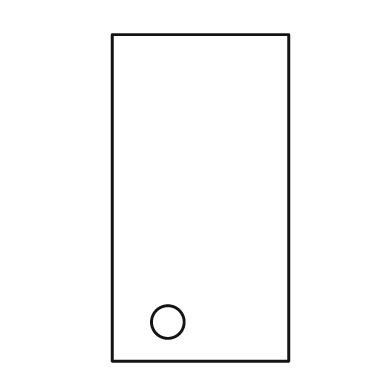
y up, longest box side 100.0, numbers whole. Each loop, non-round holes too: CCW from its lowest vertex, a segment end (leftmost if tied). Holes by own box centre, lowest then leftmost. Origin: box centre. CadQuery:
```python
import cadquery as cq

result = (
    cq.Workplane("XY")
    .moveTo(-27.0, -50.0)
    .lineTo(27.0, -50.0)
    .lineTo(27.0, 50.0)
    .lineTo(-27.0, 50.0)
    .close()
    .moveTo(-10.0, -38.0)
    .circle(5.0)
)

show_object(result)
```